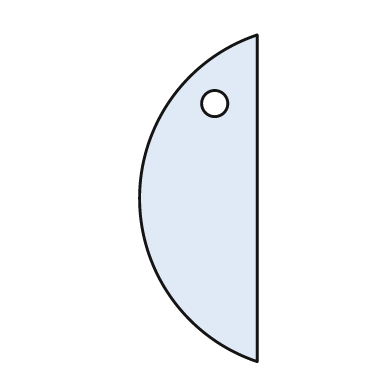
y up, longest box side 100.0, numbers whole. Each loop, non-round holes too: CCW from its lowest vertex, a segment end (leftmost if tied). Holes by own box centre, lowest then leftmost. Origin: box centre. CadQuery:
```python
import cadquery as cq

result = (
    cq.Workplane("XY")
    .moveTo(18.0, -50.0)
    .lineTo(18.0, 50.0)
    .threePointArc((-18.0, 0.0), (18.0, -50.0))
    .close()
    .moveTo(5.0, 29.0)
    .circle(4.0)
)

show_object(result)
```